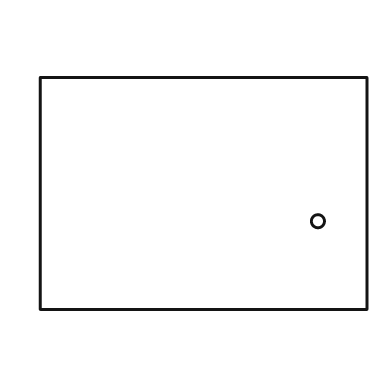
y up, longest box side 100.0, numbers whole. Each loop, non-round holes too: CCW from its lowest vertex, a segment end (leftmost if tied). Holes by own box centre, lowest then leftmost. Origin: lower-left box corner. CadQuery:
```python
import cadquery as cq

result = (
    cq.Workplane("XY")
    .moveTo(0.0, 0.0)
    .lineTo(100.0, 0.0)
    .lineTo(100.0, 71.0)
    .lineTo(0.0, 71.0)
    .close()
    .moveTo(85.0, 27.0)
    .circle(2.0)
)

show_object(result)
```